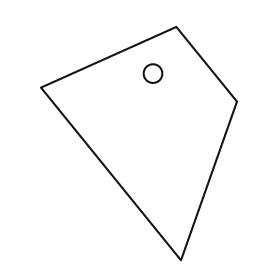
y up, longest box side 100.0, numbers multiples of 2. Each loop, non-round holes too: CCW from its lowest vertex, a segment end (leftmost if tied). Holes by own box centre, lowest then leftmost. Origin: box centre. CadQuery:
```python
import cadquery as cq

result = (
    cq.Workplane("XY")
    .moveTo(18.0, -50.0)
    .lineTo(42.0, 18.0)
    .lineTo(16.0, 50.0)
    .lineTo(-42.0, 24.0)
    .close()
    .moveTo(6.0, 30.0)
    .circle(4.0)
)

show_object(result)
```